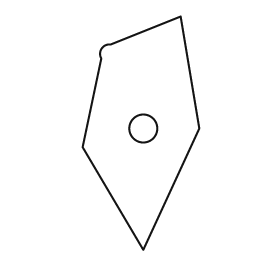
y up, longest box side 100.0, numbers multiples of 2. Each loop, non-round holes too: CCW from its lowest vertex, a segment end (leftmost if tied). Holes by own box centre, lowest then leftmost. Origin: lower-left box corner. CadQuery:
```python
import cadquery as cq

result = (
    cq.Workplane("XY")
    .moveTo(26.0, 0.0)
    .lineTo(50.0, 52.0)
    .lineTo(42.0, 100.0)
    .lineTo(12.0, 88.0)
    .threePointArc((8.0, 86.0), (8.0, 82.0))
    .lineTo(0.0, 44.0)
    .close()
    .moveTo(26.0, 52.0)
    .circle(6.0)
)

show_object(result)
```